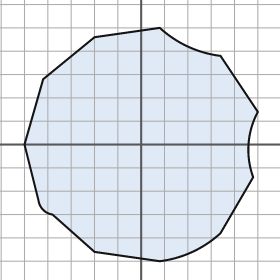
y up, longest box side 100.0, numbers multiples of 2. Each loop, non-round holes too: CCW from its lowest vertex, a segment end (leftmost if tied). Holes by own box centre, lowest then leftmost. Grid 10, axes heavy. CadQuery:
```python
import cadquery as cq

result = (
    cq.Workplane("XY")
    .moveTo(8.0, -50.0)
    .threePointArc((22.0, -46.0), (34.0, -38.0))
    .lineTo(48.0, -14.0)
    .threePointArc((46.0, 0.0), (50.0, 14.0))
    .lineTo(34.0, 38.0)
    .threePointArc((20.0, 42.0), (8.0, 50.0))
    .lineTo(-20.0, 46.0)
    .lineTo(-42.0, 28.0)
    .lineTo(-50.0, 0.0)
    .lineTo(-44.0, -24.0)
    .threePointArc((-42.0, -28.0), (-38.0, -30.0))
    .lineTo(-20.0, -46.0)
    .close()
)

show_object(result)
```